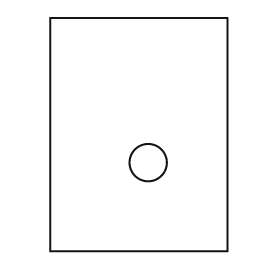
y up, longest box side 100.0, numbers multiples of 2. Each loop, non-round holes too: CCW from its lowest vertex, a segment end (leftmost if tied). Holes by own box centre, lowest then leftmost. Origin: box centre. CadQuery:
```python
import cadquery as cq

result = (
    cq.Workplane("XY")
    .moveTo(-38.0, -50.0)
    .lineTo(38.0, -50.0)
    .lineTo(38.0, 50.0)
    .lineTo(-38.0, 50.0)
    .close()
    .moveTo(4.0, -12.0)
    .circle(8.0)
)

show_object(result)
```